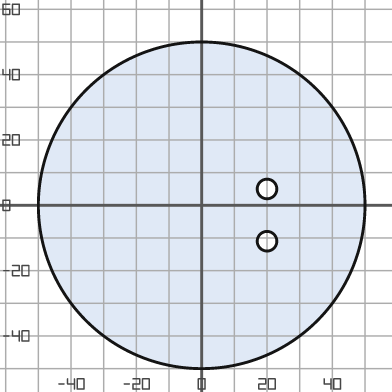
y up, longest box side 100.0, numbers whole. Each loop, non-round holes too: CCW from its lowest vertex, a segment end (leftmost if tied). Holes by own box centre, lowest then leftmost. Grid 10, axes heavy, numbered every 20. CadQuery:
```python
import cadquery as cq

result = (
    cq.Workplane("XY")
    .moveTo(0.0, 0.0)
    .circle(50.0)
    .moveTo(20.0, -11.0)
    .circle(3.0)
    .moveTo(20.0, 5.0)
    .circle(3.0)
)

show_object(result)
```